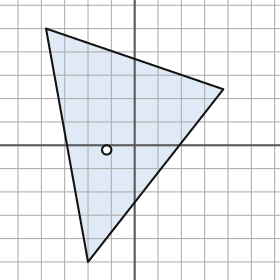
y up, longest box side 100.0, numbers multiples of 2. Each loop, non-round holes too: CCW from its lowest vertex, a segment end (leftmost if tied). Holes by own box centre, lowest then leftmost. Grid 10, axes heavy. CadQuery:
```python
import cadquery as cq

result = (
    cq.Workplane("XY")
    .moveTo(-20.0, -50.0)
    .lineTo(38.0, 24.0)
    .lineTo(-38.0, 50.0)
    .close()
    .moveTo(-12.0, -2.0)
    .circle(2.0)
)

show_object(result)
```